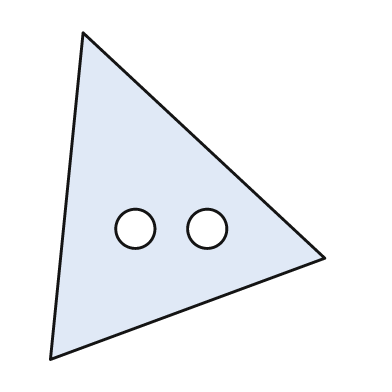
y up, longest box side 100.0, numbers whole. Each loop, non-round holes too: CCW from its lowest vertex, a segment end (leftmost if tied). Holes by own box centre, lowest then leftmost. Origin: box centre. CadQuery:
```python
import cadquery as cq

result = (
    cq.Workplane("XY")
    .moveTo(-42.0, -50.0)
    .lineTo(42.0, -19.0)
    .lineTo(-32.0, 50.0)
    .close()
    .moveTo(-16.0, -10.0)
    .circle(6.0)
    .moveTo(6.0, -10.0)
    .circle(6.0)
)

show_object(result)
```